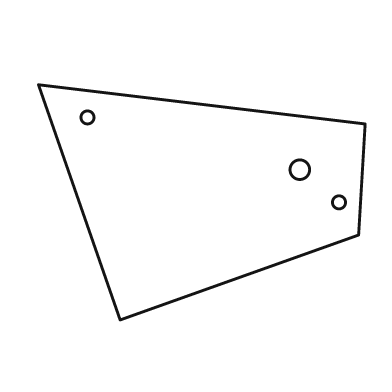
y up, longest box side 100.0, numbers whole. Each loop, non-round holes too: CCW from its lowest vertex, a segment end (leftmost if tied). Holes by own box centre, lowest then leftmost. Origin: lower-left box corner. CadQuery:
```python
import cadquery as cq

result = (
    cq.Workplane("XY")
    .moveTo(25.0, 0.0)
    .lineTo(98.0, 26.0)
    .lineTo(100.0, 60.0)
    .lineTo(0.0, 72.0)
    .close()
    .moveTo(92.0, 36.0)
    .circle(2.0)
    .moveTo(80.0, 46.0)
    .circle(3.0)
    .moveTo(15.0, 62.0)
    .circle(2.0)
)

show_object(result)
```